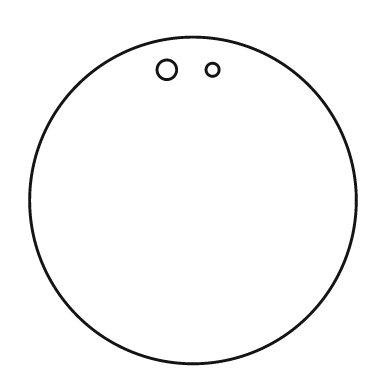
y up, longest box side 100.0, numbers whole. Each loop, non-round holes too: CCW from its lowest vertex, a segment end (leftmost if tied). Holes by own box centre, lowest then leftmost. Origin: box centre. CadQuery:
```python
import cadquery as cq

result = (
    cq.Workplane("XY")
    .moveTo(0.0, 0.0)
    .circle(50.0)
    .moveTo(-8.0, 40.0)
    .circle(3.0)
    .moveTo(6.0, 40.0)
    .circle(2.0)
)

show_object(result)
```